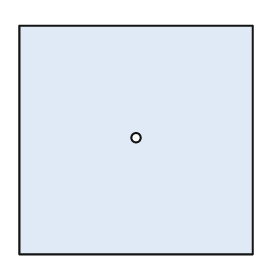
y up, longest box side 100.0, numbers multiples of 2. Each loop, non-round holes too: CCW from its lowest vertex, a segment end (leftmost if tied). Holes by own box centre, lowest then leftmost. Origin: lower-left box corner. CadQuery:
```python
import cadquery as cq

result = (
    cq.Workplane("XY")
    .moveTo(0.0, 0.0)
    .lineTo(100.0, 0.0)
    .lineTo(100.0, 98.0)
    .lineTo(0.0, 98.0)
    .close()
    .moveTo(50.0, 50.0)
    .circle(2.0)
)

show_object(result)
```